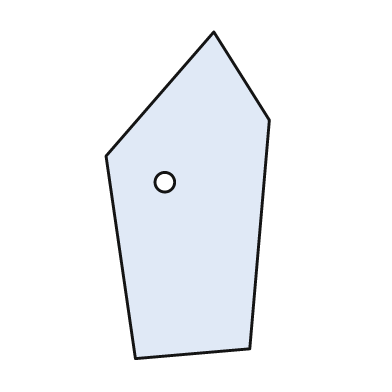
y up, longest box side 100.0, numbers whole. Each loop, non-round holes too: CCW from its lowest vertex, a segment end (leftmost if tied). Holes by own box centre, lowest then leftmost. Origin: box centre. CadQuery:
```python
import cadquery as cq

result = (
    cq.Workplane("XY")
    .moveTo(-16.0, -50.0)
    .lineTo(19.0, -47.0)
    .lineTo(25.0, 23.0)
    .lineTo(8.0, 50.0)
    .lineTo(-25.0, 12.0)
    .close()
    .moveTo(-7.0, 4.0)
    .circle(3.0)
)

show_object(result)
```